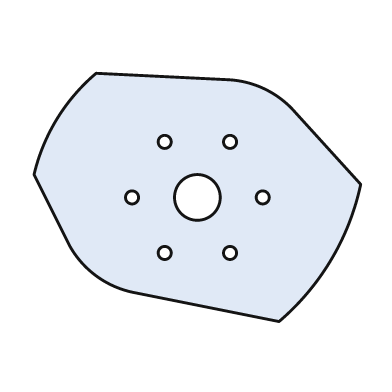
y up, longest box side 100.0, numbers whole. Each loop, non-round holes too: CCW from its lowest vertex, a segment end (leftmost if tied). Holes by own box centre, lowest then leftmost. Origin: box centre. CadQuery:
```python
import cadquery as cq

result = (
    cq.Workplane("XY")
    .moveTo(25.0, -38.0)
    .threePointArc((41.0, -19.0), (50.0, 4.0))
    .lineTo(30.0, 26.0)
    .threePointArc((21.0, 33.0), (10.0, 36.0))
    .lineTo(-31.0, 38.0)
    .threePointArc((-43.0, 24.0), (-50.0, 7.0))
    .lineTo(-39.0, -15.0)
    .threePointArc((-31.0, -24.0), (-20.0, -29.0))
    .close()
    .moveTo(-10.0, -17.0)
    .circle(2.0)
    .moveTo(10.0, -17.0)
    .circle(2.0)
    .moveTo(-20.0, 0.0)
    .circle(2.0)
    .moveTo(0.0, 0.0)
    .circle(7.0)
    .moveTo(20.0, 0.0)
    .circle(2.0)
    .moveTo(-10.0, 17.0)
    .circle(2.0)
    .moveTo(10.0, 17.0)
    .circle(2.0)
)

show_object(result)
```